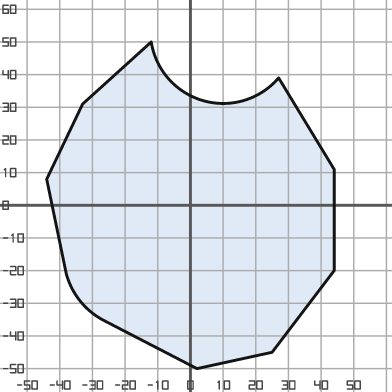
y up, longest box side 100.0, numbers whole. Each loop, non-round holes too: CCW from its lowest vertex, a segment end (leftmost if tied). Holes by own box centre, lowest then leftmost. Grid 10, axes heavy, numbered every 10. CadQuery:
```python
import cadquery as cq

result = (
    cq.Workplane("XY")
    .moveTo(2.0, -50.0)
    .lineTo(25.0, -45.0)
    .lineTo(44.0, -20.0)
    .lineTo(44.0, 11.0)
    .lineTo(27.0, 39.0)
    .threePointArc((4.0, 32.0), (-12.0, 50.0))
    .lineTo(-33.0, 31.0)
    .lineTo(-44.0, 8.0)
    .lineTo(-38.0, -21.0)
    .threePointArc((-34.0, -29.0), (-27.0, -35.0))
    .close()
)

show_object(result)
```